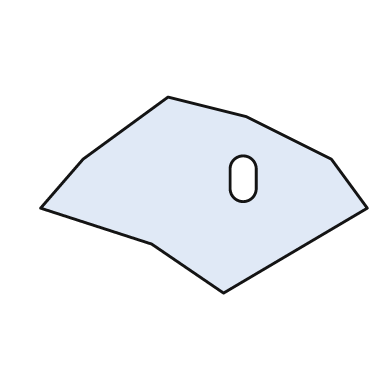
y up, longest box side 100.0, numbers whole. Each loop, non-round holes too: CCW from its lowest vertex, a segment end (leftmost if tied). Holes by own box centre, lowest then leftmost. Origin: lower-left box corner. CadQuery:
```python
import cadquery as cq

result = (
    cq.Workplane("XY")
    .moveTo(56.0, 0.0)
    .lineTo(100.0, 26.0)
    .lineTo(89.0, 41.0)
    .lineTo(63.0, 54.0)
    .lineTo(39.0, 60.0)
    .lineTo(13.0, 41.0)
    .lineTo(0.0, 26.0)
    .lineTo(34.0, 15.0)
    .close()
    .moveTo(58.0, 32.0)
    .threePointArc((62.0, 28.0), (66.0, 32.0))
    .lineTo(66.0, 38.0)
    .threePointArc((62.0, 42.0), (58.0, 38.0))
    .close()
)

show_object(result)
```